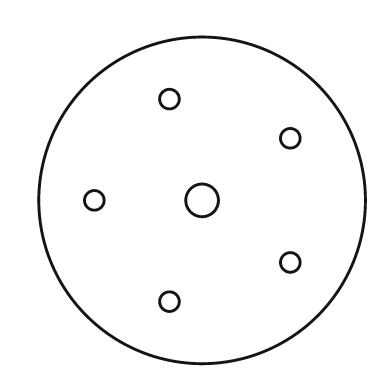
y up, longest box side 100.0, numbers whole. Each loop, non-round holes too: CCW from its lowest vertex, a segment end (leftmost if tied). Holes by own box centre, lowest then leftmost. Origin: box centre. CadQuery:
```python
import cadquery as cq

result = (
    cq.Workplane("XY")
    .moveTo(0.0, 0.0)
    .circle(50.0)
    .moveTo(-10.0, -31.0)
    .circle(3.0)
    .moveTo(27.0, -19.0)
    .circle(3.0)
    .moveTo(-33.0, 0.0)
    .circle(3.0)
    .moveTo(0.0, 0.0)
    .circle(5.0)
    .moveTo(27.0, 19.0)
    .circle(3.0)
    .moveTo(-10.0, 31.0)
    .circle(3.0)
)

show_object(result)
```